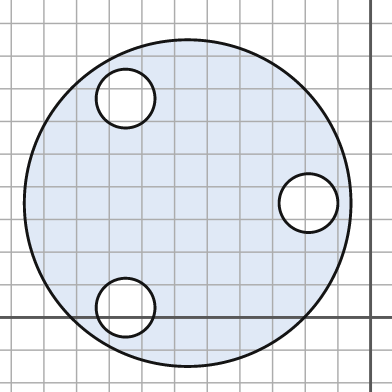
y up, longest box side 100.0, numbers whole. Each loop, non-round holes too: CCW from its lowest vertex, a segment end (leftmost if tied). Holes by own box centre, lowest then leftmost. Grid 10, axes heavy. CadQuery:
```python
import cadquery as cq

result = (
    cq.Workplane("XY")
    .moveTo(-56.0, 35.0)
    .circle(50.0)
    .moveTo(-75.0, 3.0)
    .circle(9.0)
    .moveTo(-19.0, 35.0)
    .circle(9.0)
    .moveTo(-75.0, 67.0)
    .circle(9.0)
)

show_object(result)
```